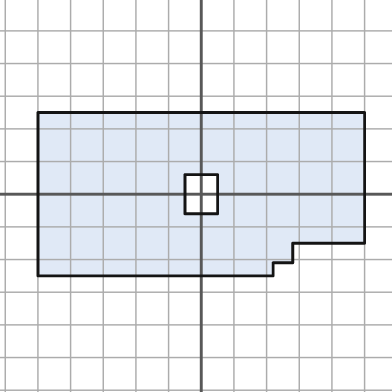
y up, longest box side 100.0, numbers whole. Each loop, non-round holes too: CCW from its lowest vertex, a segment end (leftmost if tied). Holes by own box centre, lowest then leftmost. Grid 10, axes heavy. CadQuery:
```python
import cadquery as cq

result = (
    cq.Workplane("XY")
    .moveTo(-50.0, -25.0)
    .lineTo(22.0, -25.0)
    .lineTo(22.0, -21.0)
    .lineTo(28.0, -21.0)
    .lineTo(28.0, -15.0)
    .lineTo(50.0, -15.0)
    .lineTo(50.0, 25.0)
    .lineTo(-50.0, 25.0)
    .close()
    .moveTo(-5.0, -6.0)
    .lineTo(5.0, -6.0)
    .lineTo(5.0, 6.0)
    .lineTo(-5.0, 6.0)
    .close()
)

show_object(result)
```